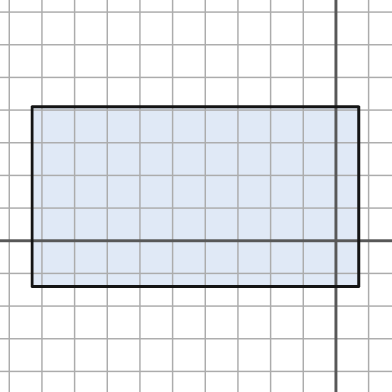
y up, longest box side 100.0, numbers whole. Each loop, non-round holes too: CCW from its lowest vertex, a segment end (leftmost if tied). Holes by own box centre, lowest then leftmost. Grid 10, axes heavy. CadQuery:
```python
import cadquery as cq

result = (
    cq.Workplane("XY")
    .moveTo(-93.0, -14.0)
    .lineTo(7.0, -14.0)
    .lineTo(7.0, 41.0)
    .lineTo(-93.0, 41.0)
    .close()
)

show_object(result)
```